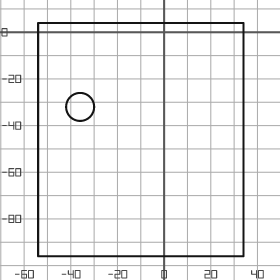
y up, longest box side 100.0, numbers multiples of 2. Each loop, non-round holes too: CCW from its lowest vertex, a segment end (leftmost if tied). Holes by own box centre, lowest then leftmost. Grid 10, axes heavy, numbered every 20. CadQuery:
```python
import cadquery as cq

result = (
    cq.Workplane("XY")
    .moveTo(-54.0, -96.0)
    .lineTo(34.0, -96.0)
    .lineTo(34.0, 4.0)
    .lineTo(-54.0, 4.0)
    .close()
    .moveTo(-36.0, -32.0)
    .circle(6.0)
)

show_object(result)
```